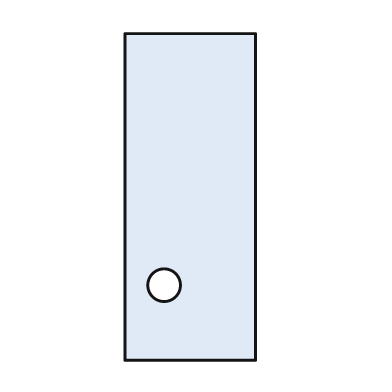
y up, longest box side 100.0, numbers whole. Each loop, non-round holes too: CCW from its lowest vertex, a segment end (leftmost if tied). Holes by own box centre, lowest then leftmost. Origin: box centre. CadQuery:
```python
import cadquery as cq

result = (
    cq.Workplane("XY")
    .moveTo(-20.0, -50.0)
    .lineTo(20.0, -50.0)
    .lineTo(20.0, 50.0)
    .lineTo(-20.0, 50.0)
    .close()
    .moveTo(-8.0, -27.0)
    .circle(5.0)
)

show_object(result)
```